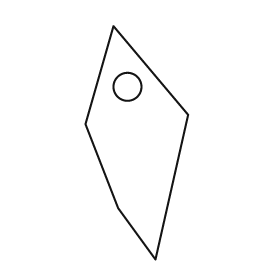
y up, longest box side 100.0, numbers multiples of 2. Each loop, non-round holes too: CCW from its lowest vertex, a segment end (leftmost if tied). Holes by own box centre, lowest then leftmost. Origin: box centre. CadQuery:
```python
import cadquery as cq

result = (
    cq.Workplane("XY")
    .moveTo(8.0, -50.0)
    .lineTo(22.0, 12.0)
    .lineTo(-10.0, 50.0)
    .lineTo(-22.0, 8.0)
    .lineTo(-8.0, -28.0)
    .close()
    .moveTo(-4.0, 24.0)
    .circle(6.0)
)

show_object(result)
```